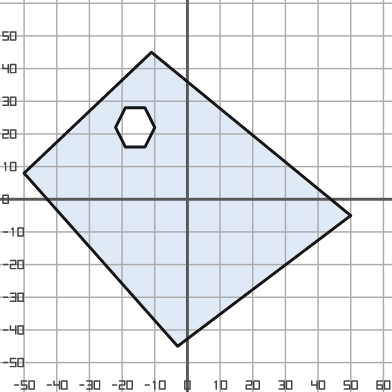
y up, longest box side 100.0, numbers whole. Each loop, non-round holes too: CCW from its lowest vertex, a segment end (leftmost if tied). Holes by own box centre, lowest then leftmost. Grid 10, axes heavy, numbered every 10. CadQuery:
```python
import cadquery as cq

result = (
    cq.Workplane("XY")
    .moveTo(-3.0, -45.0)
    .lineTo(50.0, -5.0)
    .lineTo(-11.0, 45.0)
    .lineTo(-50.0, 8.0)
    .close()
    .moveTo(-19.0, 16.0)
    .lineTo(-13.0, 16.0)
    .lineTo(-10.0, 22.0)
    .lineTo(-13.0, 28.0)
    .lineTo(-19.0, 28.0)
    .lineTo(-22.0, 22.0)
    .close()
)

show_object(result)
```